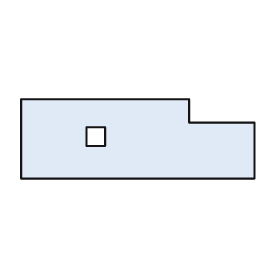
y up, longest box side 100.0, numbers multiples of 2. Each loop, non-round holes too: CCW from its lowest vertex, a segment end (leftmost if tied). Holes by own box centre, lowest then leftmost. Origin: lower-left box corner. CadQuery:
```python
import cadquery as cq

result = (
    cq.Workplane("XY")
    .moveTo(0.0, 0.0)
    .lineTo(100.0, 0.0)
    .lineTo(100.0, 24.0)
    .lineTo(72.0, 24.0)
    .lineTo(72.0, 34.0)
    .lineTo(0.0, 34.0)
    .close()
    .moveTo(28.0, 14.0)
    .lineTo(36.0, 14.0)
    .lineTo(36.0, 22.0)
    .lineTo(28.0, 22.0)
    .close()
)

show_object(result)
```